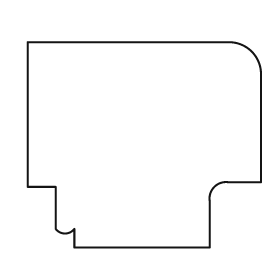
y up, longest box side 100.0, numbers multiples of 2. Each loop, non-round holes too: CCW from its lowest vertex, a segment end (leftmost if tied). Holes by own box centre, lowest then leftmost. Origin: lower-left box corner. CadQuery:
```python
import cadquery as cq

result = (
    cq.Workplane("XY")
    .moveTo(20.0, 0.0)
    .lineTo(78.0, 0.0)
    .lineTo(78.0, 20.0)
    .threePointArc((80.0, 26.0), (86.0, 28.0))
    .lineTo(100.0, 28.0)
    .lineTo(100.0, 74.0)
    .threePointArc((96.0, 84.0), (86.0, 88.0))
    .lineTo(0.0, 88.0)
    .lineTo(0.0, 26.0)
    .lineTo(12.0, 26.0)
    .lineTo(12.0, 8.0)
    .threePointArc((16.0, 6.0), (20.0, 8.0))
    .close()
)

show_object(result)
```